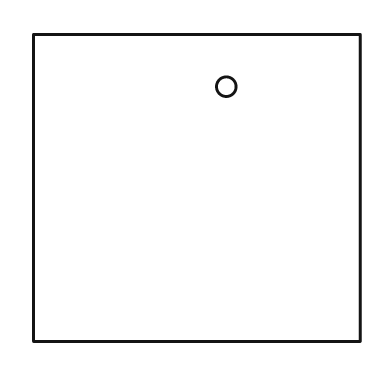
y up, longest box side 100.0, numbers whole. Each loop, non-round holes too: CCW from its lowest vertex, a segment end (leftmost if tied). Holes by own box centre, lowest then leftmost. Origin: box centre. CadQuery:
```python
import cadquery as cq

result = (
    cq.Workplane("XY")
    .moveTo(-50.0, -47.0)
    .lineTo(50.0, -47.0)
    .lineTo(50.0, 47.0)
    .lineTo(-50.0, 47.0)
    .close()
    .moveTo(9.0, 31.0)
    .circle(3.0)
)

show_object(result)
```